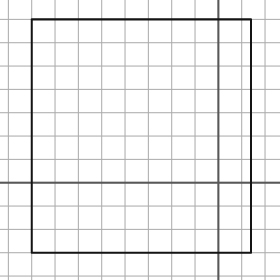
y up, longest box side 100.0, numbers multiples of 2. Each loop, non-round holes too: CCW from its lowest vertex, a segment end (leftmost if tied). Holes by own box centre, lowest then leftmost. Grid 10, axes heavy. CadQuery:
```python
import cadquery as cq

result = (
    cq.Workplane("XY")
    .moveTo(-80.0, -30.0)
    .lineTo(14.0, -30.0)
    .lineTo(14.0, 70.0)
    .lineTo(-80.0, 70.0)
    .close()
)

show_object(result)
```